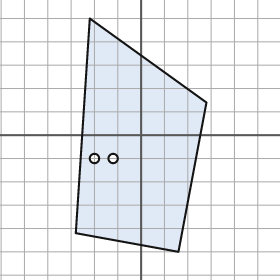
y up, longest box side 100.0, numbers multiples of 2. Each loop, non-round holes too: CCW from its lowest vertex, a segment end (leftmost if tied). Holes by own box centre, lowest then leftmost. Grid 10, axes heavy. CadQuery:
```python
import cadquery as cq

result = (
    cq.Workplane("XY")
    .moveTo(16.0, -50.0)
    .lineTo(28.0, 14.0)
    .lineTo(-22.0, 50.0)
    .lineTo(-28.0, -42.0)
    .close()
    .moveTo(-20.0, -10.0)
    .circle(2.0)
    .moveTo(-12.0, -10.0)
    .circle(2.0)
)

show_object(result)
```